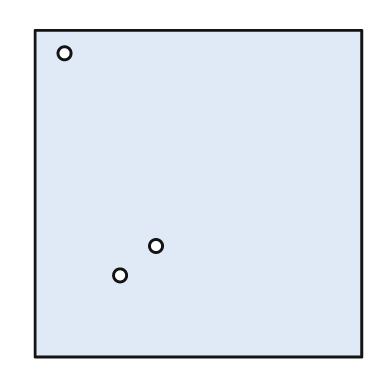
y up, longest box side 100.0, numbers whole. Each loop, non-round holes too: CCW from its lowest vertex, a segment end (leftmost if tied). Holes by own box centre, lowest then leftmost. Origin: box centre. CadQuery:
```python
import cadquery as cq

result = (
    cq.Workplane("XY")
    .moveTo(-50.0, -50.0)
    .lineTo(50.0, -50.0)
    .lineTo(50.0, 50.0)
    .lineTo(-50.0, 50.0)
    .close()
    .moveTo(-24.0, -25.0)
    .circle(2.0)
    .moveTo(-13.0, -16.0)
    .circle(2.0)
    .moveTo(-41.0, 43.0)
    .circle(2.0)
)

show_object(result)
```